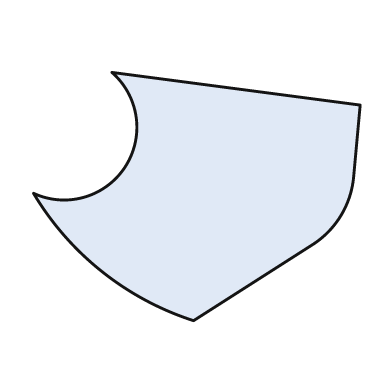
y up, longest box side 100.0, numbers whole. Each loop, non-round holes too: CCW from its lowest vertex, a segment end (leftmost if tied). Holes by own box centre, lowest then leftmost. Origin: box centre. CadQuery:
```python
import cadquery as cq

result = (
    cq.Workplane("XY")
    .moveTo(-1.0, -38.0)
    .lineTo(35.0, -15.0)
    .threePointArc((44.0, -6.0), (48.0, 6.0))
    .lineTo(50.0, 28.0)
    .lineTo(-26.0, 38.0)
    .threePointArc((-22.0, 9.0), (-50.0, 1.0))
    .threePointArc((-29.0, -23.0), (-1.0, -38.0))
    .close()
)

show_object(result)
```